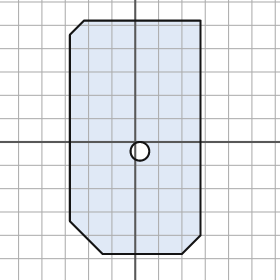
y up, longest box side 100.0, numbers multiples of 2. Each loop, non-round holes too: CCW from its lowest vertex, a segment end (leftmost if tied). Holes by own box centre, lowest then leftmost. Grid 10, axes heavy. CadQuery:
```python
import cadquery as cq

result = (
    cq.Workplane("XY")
    .moveTo(-14.0, -48.0)
    .lineTo(20.0, -48.0)
    .lineTo(28.0, -40.0)
    .lineTo(28.0, 52.0)
    .lineTo(-22.0, 52.0)
    .lineTo(-28.0, 46.0)
    .lineTo(-28.0, -34.0)
    .close()
    .moveTo(2.0, -4.0)
    .circle(4.0)
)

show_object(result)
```